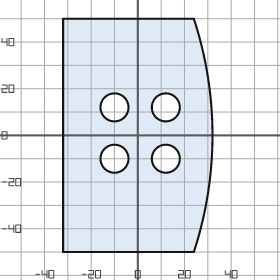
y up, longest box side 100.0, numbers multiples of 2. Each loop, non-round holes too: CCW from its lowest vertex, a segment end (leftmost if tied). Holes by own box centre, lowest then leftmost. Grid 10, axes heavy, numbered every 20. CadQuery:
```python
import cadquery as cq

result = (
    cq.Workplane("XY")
    .moveTo(-32.0, -50.0)
    .lineTo(24.0, -50.0)
    .threePointArc((32.0, 0.0), (24.0, 50.0))
    .lineTo(-32.0, 50.0)
    .close()
    .moveTo(-10.0, -10.0)
    .circle(6.0)
    .moveTo(12.0, -10.0)
    .circle(6.0)
    .moveTo(-10.0, 12.0)
    .circle(6.0)
    .moveTo(12.0, 12.0)
    .circle(6.0)
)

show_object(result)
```